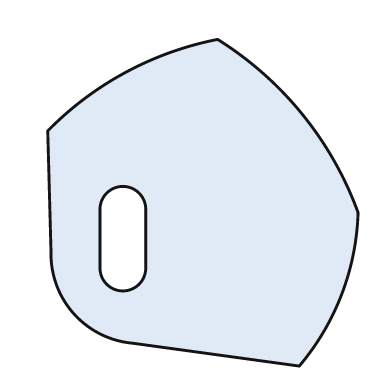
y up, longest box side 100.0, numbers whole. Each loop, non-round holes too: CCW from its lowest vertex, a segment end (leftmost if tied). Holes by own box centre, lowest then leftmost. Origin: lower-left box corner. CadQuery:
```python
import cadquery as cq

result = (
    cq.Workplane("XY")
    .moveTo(77.0, 0.0)
    .threePointArc((90.0, 22.0), (95.0, 47.0))
    .threePointArc((78.0, 77.0), (52.0, 100.0))
    .threePointArc((24.0, 90.0), (0.0, 72.0))
    .lineTo(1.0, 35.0)
    .threePointArc((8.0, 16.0), (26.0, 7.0))
    .close()
    .moveTo(16.0, 30.0)
    .threePointArc((23.0, 23.0), (30.0, 30.0))
    .lineTo(30.0, 48.0)
    .threePointArc((23.0, 55.0), (16.0, 48.0))
    .close()
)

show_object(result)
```